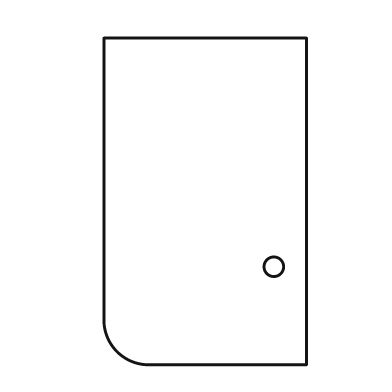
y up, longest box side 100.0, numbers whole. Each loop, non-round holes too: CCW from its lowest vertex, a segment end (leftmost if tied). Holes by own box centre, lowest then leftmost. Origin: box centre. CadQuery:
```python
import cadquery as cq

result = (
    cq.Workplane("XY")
    .moveTo(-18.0, -50.0)
    .lineTo(31.0, -50.0)
    .lineTo(31.0, 50.0)
    .lineTo(-31.0, 50.0)
    .lineTo(-31.0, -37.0)
    .threePointArc((-27.0, -46.0), (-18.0, -50.0))
    .close()
    .moveTo(21.0, -20.0)
    .circle(3.0)
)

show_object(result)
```